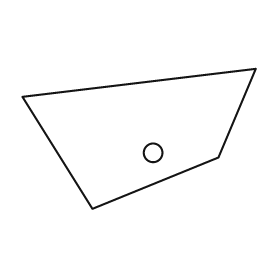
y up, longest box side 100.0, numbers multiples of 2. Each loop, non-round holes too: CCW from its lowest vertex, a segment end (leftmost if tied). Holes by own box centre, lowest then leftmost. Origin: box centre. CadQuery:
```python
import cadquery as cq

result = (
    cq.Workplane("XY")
    .moveTo(-20.0, -30.0)
    .lineTo(34.0, -8.0)
    .lineTo(50.0, 30.0)
    .lineTo(-50.0, 18.0)
    .close()
    .moveTo(6.0, -6.0)
    .circle(4.0)
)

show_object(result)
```